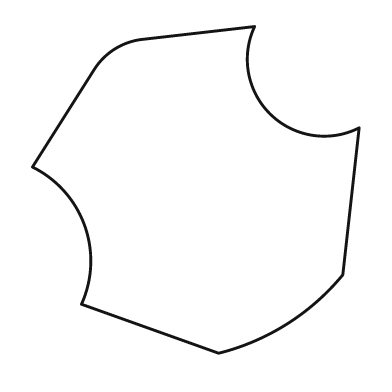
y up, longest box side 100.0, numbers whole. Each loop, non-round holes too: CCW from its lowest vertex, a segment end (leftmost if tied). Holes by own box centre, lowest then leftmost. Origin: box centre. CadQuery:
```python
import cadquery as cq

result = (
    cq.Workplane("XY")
    .moveTo(7.0, -50.0)
    .threePointArc((28.0, -41.0), (45.0, -26.0))
    .lineTo(50.0, 19.0)
    .threePointArc((23.0, 23.0), (18.0, 50.0))
    .lineTo(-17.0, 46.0)
    .threePointArc((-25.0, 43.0), (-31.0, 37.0))
    .lineTo(-50.0, 7.0)
    .threePointArc((-34.0, -11.0), (-35.0, -35.0))
    .close()
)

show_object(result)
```